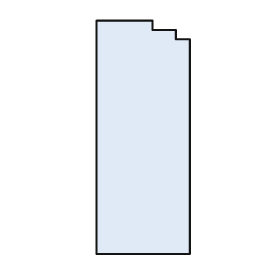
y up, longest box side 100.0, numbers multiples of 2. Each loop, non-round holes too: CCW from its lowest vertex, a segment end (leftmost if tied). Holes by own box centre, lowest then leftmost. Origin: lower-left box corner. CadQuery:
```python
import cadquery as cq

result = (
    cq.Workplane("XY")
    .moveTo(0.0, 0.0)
    .lineTo(40.0, 0.0)
    .lineTo(40.0, 92.0)
    .lineTo(34.0, 92.0)
    .lineTo(34.0, 96.0)
    .lineTo(24.0, 96.0)
    .lineTo(24.0, 100.0)
    .lineTo(0.0, 100.0)
    .close()
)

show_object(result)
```